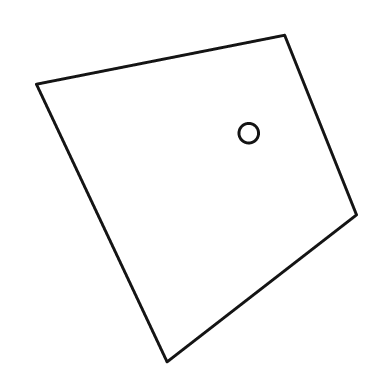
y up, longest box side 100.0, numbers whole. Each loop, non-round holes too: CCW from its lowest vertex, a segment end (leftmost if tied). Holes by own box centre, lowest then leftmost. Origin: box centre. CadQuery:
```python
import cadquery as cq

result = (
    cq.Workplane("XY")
    .moveTo(-9.0, -50.0)
    .lineTo(49.0, -5.0)
    .lineTo(27.0, 50.0)
    .lineTo(-49.0, 35.0)
    .close()
    .moveTo(16.0, 20.0)
    .circle(3.0)
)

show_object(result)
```